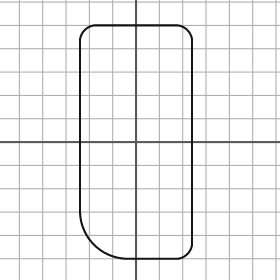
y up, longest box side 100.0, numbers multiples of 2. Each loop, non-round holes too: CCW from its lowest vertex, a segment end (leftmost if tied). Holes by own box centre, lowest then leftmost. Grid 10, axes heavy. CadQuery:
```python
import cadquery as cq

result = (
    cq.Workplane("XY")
    .moveTo(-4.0, -50.0)
    .lineTo(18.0, -50.0)
    .threePointArc((22.0, -48.0), (24.0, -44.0))
    .lineTo(24.0, 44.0)
    .threePointArc((22.0, 48.0), (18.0, 50.0))
    .lineTo(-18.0, 50.0)
    .threePointArc((-22.0, 48.0), (-24.0, 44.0))
    .lineTo(-24.0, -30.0)
    .threePointArc((-18.0, -44.0), (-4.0, -50.0))
    .close()
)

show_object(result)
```